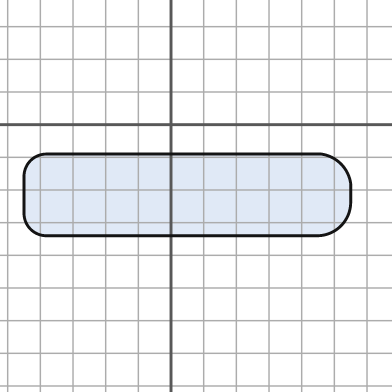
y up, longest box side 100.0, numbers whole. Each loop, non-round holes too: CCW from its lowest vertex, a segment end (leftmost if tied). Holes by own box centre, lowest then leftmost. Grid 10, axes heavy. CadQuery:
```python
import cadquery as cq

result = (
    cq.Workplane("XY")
    .moveTo(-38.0, -34.0)
    .lineTo(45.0, -34.0)
    .threePointArc((52.0, -31.0), (55.0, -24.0))
    .lineTo(55.0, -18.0)
    .threePointArc((52.0, -12.0), (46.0, -9.0))
    .lineTo(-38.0, -9.0)
    .threePointArc((-43.0, -11.0), (-45.0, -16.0))
    .lineTo(-45.0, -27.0)
    .threePointArc((-43.0, -32.0), (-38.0, -34.0))
    .close()
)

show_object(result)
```